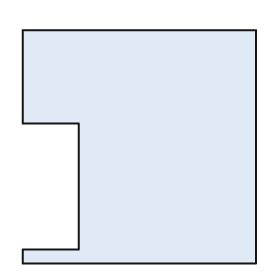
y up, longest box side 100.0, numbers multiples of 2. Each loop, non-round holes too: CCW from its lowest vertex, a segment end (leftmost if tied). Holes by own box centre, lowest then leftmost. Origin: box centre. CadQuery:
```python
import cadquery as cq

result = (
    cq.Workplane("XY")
    .moveTo(-50.0, -50.0)
    .lineTo(50.0, -50.0)
    .lineTo(50.0, 50.0)
    .lineTo(-50.0, 50.0)
    .lineTo(-50.0, 10.0)
    .lineTo(-26.0, 10.0)
    .lineTo(-26.0, -44.0)
    .lineTo(-50.0, -44.0)
    .close()
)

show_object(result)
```